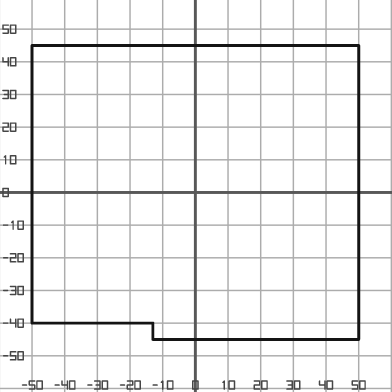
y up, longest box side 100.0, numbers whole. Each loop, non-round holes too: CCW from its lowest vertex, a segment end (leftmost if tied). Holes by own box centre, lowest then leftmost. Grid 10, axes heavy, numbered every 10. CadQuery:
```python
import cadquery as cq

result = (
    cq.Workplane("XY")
    .moveTo(-13.0, -45.0)
    .lineTo(50.0, -45.0)
    .lineTo(50.0, 45.0)
    .lineTo(-50.0, 45.0)
    .lineTo(-50.0, -40.0)
    .lineTo(-13.0, -40.0)
    .close()
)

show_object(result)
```